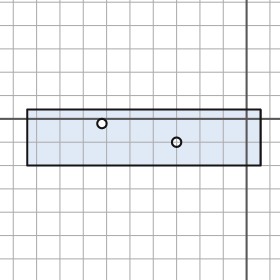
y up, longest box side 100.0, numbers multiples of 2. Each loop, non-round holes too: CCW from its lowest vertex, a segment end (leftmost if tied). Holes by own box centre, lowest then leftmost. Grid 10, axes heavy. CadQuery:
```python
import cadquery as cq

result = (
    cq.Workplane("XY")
    .moveTo(-94.0, -20.0)
    .lineTo(6.0, -20.0)
    .lineTo(6.0, 4.0)
    .lineTo(-94.0, 4.0)
    .close()
    .moveTo(-30.0, -10.0)
    .circle(2.0)
    .moveTo(-62.0, -2.0)
    .circle(2.0)
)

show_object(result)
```